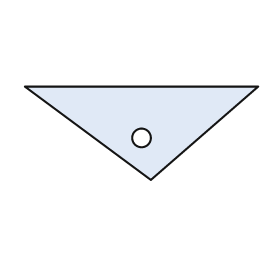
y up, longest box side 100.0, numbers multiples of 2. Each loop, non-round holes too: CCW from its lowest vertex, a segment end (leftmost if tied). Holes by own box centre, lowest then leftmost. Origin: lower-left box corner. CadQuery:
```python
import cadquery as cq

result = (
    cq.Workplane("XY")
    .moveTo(54.0, 0.0)
    .lineTo(100.0, 40.0)
    .lineTo(0.0, 40.0)
    .close()
    .moveTo(50.0, 18.0)
    .circle(4.0)
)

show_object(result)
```